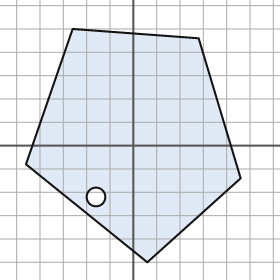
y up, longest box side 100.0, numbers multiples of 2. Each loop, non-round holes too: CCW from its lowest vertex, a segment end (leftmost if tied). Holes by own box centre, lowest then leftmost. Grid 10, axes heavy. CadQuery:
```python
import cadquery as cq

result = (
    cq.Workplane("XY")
    .moveTo(6.0, -50.0)
    .lineTo(46.0, -14.0)
    .lineTo(28.0, 46.0)
    .lineTo(-26.0, 50.0)
    .lineTo(-46.0, -8.0)
    .close()
    .moveTo(-16.0, -22.0)
    .circle(4.0)
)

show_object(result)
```